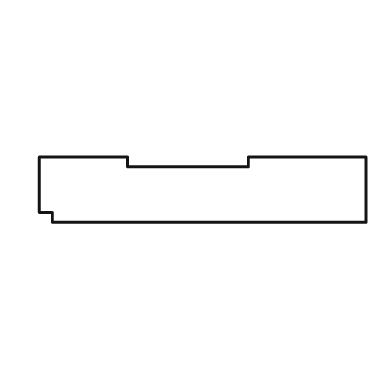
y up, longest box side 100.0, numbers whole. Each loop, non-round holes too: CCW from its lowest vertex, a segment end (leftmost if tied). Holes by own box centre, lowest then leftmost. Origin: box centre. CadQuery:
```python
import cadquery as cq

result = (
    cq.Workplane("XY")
    .moveTo(-46.0, -10.0)
    .lineTo(50.0, -10.0)
    .lineTo(50.0, 10.0)
    .lineTo(14.0, 10.0)
    .lineTo(14.0, 7.0)
    .lineTo(-23.0, 7.0)
    .lineTo(-23.0, 10.0)
    .lineTo(-50.0, 10.0)
    .lineTo(-50.0, -7.0)
    .lineTo(-46.0, -7.0)
    .close()
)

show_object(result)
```